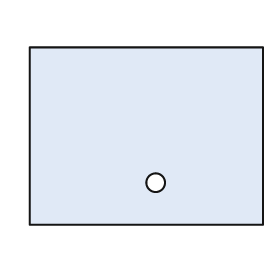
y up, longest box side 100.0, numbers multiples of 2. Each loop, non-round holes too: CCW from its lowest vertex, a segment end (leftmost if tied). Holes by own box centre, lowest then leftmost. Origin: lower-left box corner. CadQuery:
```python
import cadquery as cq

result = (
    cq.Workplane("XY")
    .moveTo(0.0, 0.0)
    .lineTo(100.0, 0.0)
    .lineTo(100.0, 76.0)
    .lineTo(0.0, 76.0)
    .close()
    .moveTo(54.0, 18.0)
    .circle(4.0)
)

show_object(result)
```